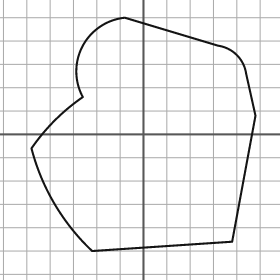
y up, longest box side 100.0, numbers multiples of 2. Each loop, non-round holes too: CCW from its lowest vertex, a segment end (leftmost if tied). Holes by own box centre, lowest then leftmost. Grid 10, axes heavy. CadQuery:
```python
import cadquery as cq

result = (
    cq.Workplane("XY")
    .moveTo(-22.0, -50.0)
    .lineTo(38.0, -46.0)
    .lineTo(48.0, 8.0)
    .lineTo(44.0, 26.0)
    .threePointArc((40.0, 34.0), (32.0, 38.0))
    .lineTo(-8.0, 50.0)
    .threePointArc((-26.0, 38.0), (-26.0, 16.0))
    .threePointArc((-38.0, 6.0), (-48.0, -6.0))
    .threePointArc((-38.0, -30.0), (-22.0, -50.0))
    .close()
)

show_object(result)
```